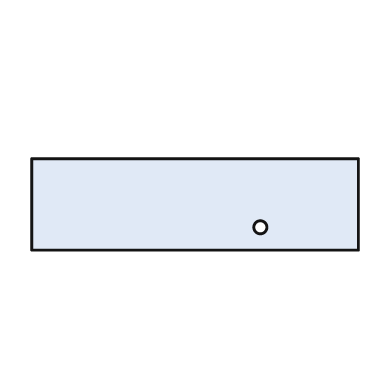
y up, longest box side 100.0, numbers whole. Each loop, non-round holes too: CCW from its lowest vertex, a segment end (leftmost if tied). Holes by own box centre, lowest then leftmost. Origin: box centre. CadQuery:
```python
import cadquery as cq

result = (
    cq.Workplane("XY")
    .moveTo(-50.0, -14.0)
    .lineTo(50.0, -14.0)
    .lineTo(50.0, 14.0)
    .lineTo(-50.0, 14.0)
    .close()
    .moveTo(20.0, -7.0)
    .circle(2.0)
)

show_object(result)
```